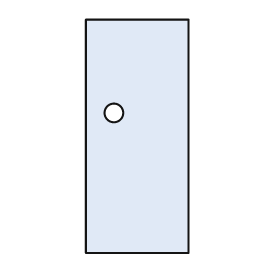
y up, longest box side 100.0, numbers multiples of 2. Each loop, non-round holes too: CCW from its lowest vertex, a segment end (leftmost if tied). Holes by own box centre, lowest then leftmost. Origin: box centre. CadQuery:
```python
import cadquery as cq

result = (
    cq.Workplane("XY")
    .moveTo(-22.0, -50.0)
    .lineTo(22.0, -50.0)
    .lineTo(22.0, 50.0)
    .lineTo(-22.0, 50.0)
    .close()
    .moveTo(-10.0, 10.0)
    .circle(4.0)
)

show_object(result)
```